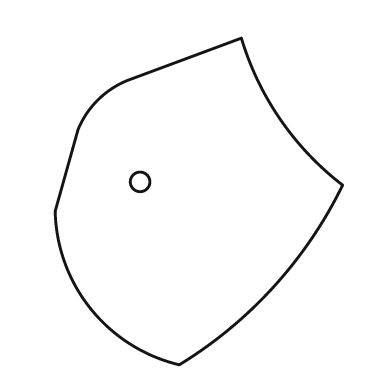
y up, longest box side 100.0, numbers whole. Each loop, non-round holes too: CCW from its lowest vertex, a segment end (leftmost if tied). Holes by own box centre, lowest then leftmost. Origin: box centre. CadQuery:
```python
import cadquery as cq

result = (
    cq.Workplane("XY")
    .moveTo(-6.0, -50.0)
    .threePointArc((23.0, -26.0), (44.0, 5.0))
    .threePointArc((25.0, 25.0), (13.0, 50.0))
    .lineTo(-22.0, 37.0)
    .threePointArc((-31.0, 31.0), (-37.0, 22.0))
    .lineTo(-44.0, -3.0)
    .threePointArc((-33.0, -33.0), (-6.0, -50.0))
    .close()
    .moveTo(-18.0, 6.0)
    .circle(3.0)
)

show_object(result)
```